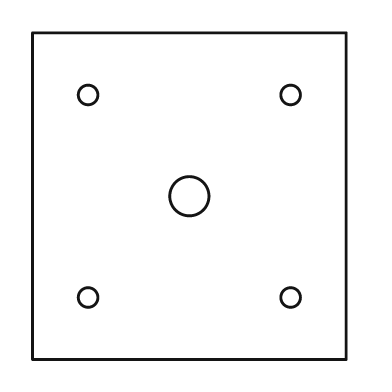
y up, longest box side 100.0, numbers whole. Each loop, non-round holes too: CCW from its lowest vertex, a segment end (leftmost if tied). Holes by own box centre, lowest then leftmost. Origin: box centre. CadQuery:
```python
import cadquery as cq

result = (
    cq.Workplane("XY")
    .moveTo(-48.0, -50.0)
    .lineTo(48.0, -50.0)
    .lineTo(48.0, 50.0)
    .lineTo(-48.0, 50.0)
    .close()
    .moveTo(-31.0, -31.0)
    .circle(3.0)
    .moveTo(31.0, -31.0)
    .circle(3.0)
    .moveTo(0.0, 0.0)
    .circle(6.0)
    .moveTo(-31.0, 31.0)
    .circle(3.0)
    .moveTo(31.0, 31.0)
    .circle(3.0)
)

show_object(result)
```